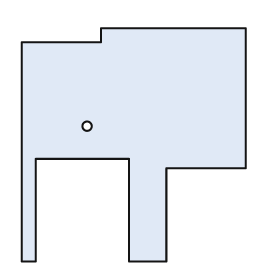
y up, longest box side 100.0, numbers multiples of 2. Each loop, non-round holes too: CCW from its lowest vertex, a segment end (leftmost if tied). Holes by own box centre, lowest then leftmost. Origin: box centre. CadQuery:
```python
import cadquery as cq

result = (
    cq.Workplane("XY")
    .moveTo(-48.0, -50.0)
    .lineTo(-42.0, -50.0)
    .lineTo(-42.0, -6.0)
    .lineTo(-2.0, -6.0)
    .lineTo(-2.0, -50.0)
    .lineTo(14.0, -50.0)
    .lineTo(14.0, -10.0)
    .lineTo(48.0, -10.0)
    .lineTo(48.0, 50.0)
    .lineTo(-14.0, 50.0)
    .lineTo(-14.0, 44.0)
    .lineTo(-48.0, 44.0)
    .close()
    .moveTo(-20.0, 8.0)
    .circle(2.0)
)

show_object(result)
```